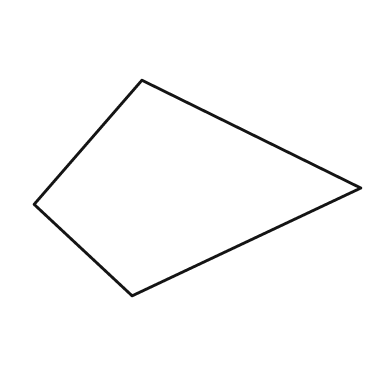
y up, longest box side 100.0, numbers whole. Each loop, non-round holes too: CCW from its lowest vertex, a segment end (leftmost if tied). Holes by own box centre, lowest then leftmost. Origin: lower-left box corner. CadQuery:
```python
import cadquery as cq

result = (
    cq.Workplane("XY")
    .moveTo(30.0, 0.0)
    .lineTo(100.0, 33.0)
    .lineTo(33.0, 66.0)
    .lineTo(0.0, 28.0)
    .close()
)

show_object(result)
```